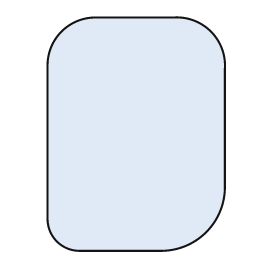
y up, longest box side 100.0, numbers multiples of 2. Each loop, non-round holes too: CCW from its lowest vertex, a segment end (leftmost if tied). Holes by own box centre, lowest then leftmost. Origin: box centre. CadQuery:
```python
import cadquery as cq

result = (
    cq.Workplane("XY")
    .moveTo(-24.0, -50.0)
    .lineTo(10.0, -50.0)
    .threePointArc((30.0, -42.0), (38.0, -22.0))
    .lineTo(38.0, 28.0)
    .threePointArc((32.0, 44.0), (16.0, 50.0))
    .lineTo(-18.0, 50.0)
    .threePointArc((-32.0, 44.0), (-38.0, 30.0))
    .lineTo(-38.0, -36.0)
    .threePointArc((-34.0, -46.0), (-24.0, -50.0))
    .close()
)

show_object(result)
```